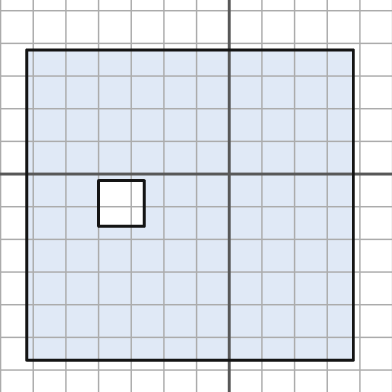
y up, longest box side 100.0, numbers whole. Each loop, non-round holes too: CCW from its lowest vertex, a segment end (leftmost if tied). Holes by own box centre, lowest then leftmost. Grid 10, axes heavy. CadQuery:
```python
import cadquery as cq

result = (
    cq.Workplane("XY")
    .moveTo(-62.0, -57.0)
    .lineTo(38.0, -57.0)
    .lineTo(38.0, 38.0)
    .lineTo(-62.0, 38.0)
    .close()
    .moveTo(-40.0, -16.0)
    .lineTo(-26.0, -16.0)
    .lineTo(-26.0, -2.0)
    .lineTo(-40.0, -2.0)
    .close()
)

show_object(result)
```